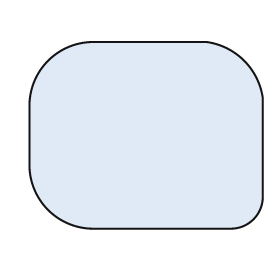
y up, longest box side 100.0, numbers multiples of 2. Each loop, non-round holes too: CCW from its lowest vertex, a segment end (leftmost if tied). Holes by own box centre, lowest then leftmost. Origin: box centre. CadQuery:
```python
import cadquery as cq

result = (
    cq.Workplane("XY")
    .moveTo(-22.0, -40.0)
    .lineTo(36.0, -40.0)
    .threePointArc((46.0, -36.0), (50.0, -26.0))
    .lineTo(50.0, 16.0)
    .threePointArc((42.0, 32.0), (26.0, 40.0))
    .lineTo(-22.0, 40.0)
    .threePointArc((-42.0, 32.0), (-50.0, 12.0))
    .lineTo(-50.0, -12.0)
    .threePointArc((-42.0, -32.0), (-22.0, -40.0))
    .close()
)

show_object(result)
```